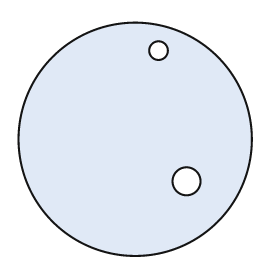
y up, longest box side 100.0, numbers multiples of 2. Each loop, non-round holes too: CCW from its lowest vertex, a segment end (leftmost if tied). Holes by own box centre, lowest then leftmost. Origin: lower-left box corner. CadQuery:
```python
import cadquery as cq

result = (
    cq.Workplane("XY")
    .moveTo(50.0, 50.0)
    .circle(50.0)
    .moveTo(72.0, 32.0)
    .circle(6.0)
    .moveTo(60.0, 88.0)
    .circle(4.0)
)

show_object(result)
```